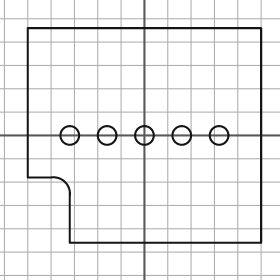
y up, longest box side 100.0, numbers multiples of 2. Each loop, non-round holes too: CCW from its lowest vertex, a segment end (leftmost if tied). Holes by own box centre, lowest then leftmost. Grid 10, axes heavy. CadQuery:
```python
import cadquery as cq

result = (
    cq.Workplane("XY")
    .moveTo(-32.0, -46.0)
    .lineTo(50.0, -46.0)
    .lineTo(50.0, 46.0)
    .lineTo(-50.0, 46.0)
    .lineTo(-50.0, -18.0)
    .lineTo(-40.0, -18.0)
    .threePointArc((-34.0, -20.0), (-32.0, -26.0))
    .close()
    .moveTo(-32.0, 0.0)
    .circle(4.0)
    .moveTo(-16.0, 0.0)
    .circle(4.0)
    .moveTo(0.0, 0.0)
    .circle(4.0)
    .moveTo(16.0, 0.0)
    .circle(4.0)
    .moveTo(32.0, 0.0)
    .circle(4.0)
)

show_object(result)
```